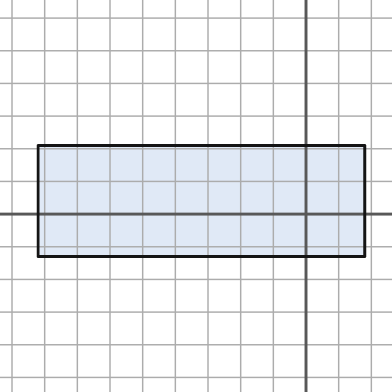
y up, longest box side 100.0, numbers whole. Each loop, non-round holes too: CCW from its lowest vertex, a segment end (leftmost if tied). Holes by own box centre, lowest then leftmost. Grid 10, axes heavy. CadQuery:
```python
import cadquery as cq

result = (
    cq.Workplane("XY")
    .moveTo(-82.0, -13.0)
    .lineTo(18.0, -13.0)
    .lineTo(18.0, 21.0)
    .lineTo(-82.0, 21.0)
    .close()
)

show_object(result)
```